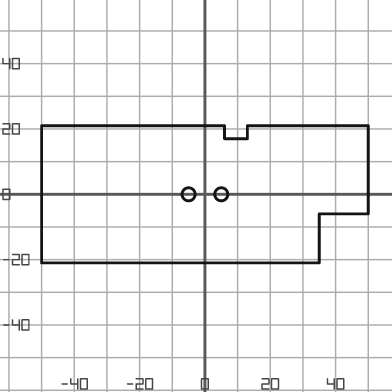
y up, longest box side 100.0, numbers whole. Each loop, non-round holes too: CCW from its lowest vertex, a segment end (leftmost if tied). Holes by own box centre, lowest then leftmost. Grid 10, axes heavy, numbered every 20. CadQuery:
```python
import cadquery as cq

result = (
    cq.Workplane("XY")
    .moveTo(-50.0, -21.0)
    .lineTo(35.0, -21.0)
    .lineTo(35.0, -6.0)
    .lineTo(50.0, -6.0)
    .lineTo(50.0, 21.0)
    .lineTo(13.0, 21.0)
    .lineTo(13.0, 17.0)
    .lineTo(6.0, 17.0)
    .lineTo(6.0, 21.0)
    .lineTo(-50.0, 21.0)
    .close()
    .moveTo(-5.0, 0.0)
    .circle(2.0)
    .moveTo(5.0, 0.0)
    .circle(2.0)
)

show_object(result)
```